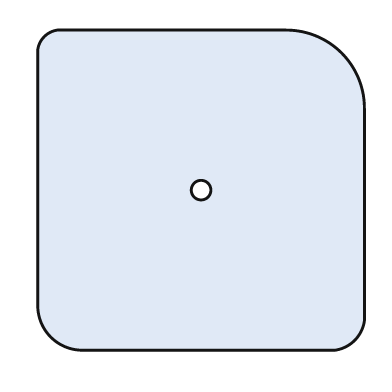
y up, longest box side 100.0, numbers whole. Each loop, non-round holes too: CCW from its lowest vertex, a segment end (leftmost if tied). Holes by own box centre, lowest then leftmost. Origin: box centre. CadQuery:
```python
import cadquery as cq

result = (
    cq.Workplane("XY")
    .moveTo(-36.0, -49.0)
    .lineTo(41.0, -49.0)
    .threePointArc((47.0, -46.0), (50.0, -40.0))
    .lineTo(50.0, 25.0)
    .threePointArc((43.0, 42.0), (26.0, 49.0))
    .lineTo(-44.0, 49.0)
    .threePointArc((-48.0, 47.0), (-50.0, 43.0))
    .lineTo(-50.0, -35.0)
    .threePointArc((-46.0, -45.0), (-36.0, -49.0))
    .close()
    .moveTo(0.0, 0.0)
    .circle(3.0)
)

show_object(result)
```